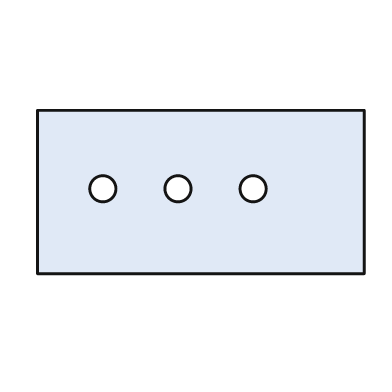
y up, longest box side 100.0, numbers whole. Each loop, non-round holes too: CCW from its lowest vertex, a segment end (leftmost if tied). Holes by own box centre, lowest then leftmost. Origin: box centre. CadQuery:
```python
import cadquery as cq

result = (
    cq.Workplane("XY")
    .moveTo(-50.0, -25.0)
    .lineTo(50.0, -25.0)
    .lineTo(50.0, 25.0)
    .lineTo(-50.0, 25.0)
    .close()
    .moveTo(-30.0, 1.0)
    .circle(4.0)
    .moveTo(-7.0, 1.0)
    .circle(4.0)
    .moveTo(16.0, 1.0)
    .circle(4.0)
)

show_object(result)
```